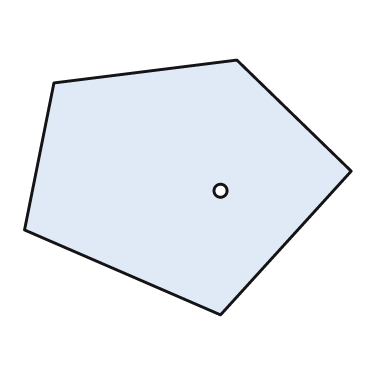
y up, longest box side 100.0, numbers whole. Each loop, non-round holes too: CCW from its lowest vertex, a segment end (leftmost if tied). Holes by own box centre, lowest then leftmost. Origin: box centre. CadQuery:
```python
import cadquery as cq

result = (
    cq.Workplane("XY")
    .moveTo(10.0, -39.0)
    .lineTo(50.0, 5.0)
    .lineTo(15.0, 39.0)
    .lineTo(-41.0, 32.0)
    .lineTo(-50.0, -13.0)
    .close()
    .moveTo(10.0, -1.0)
    .circle(2.0)
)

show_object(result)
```